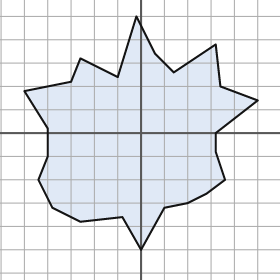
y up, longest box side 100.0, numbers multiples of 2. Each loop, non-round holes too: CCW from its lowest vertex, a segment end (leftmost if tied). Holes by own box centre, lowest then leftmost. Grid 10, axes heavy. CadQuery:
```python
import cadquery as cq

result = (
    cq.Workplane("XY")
    .moveTo(0.0, -50.0)
    .lineTo(10.0, -32.0)
    .lineTo(20.0, -30.0)
    .lineTo(28.0, -26.0)
    .lineTo(36.0, -20.0)
    .lineTo(32.0, -8.0)
    .lineTo(32.0, 0.0)
    .lineTo(50.0, 14.0)
    .lineTo(34.0, 20.0)
    .lineTo(32.0, 38.0)
    .lineTo(14.0, 26.0)
    .lineTo(6.0, 34.0)
    .lineTo(-2.0, 50.0)
    .lineTo(-10.0, 24.0)
    .lineTo(-26.0, 32.0)
    .lineTo(-30.0, 22.0)
    .lineTo(-50.0, 18.0)
    .lineTo(-40.0, 2.0)
    .lineTo(-40.0, -10.0)
    .lineTo(-44.0, -20.0)
    .lineTo(-38.0, -32.0)
    .lineTo(-26.0, -38.0)
    .lineTo(-8.0, -36.0)
    .close()
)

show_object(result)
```